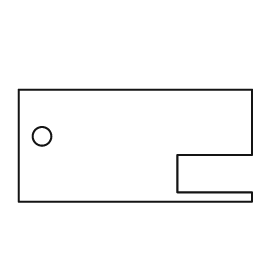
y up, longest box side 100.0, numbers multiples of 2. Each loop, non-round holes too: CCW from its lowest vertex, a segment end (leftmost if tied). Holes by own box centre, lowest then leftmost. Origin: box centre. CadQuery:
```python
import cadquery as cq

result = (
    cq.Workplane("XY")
    .moveTo(-50.0, -24.0)
    .lineTo(50.0, -24.0)
    .lineTo(50.0, -20.0)
    .lineTo(18.0, -20.0)
    .lineTo(18.0, -4.0)
    .lineTo(50.0, -4.0)
    .lineTo(50.0, 24.0)
    .lineTo(-50.0, 24.0)
    .close()
    .moveTo(-40.0, 4.0)
    .circle(4.0)
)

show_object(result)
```